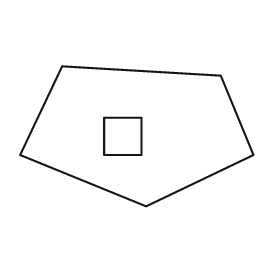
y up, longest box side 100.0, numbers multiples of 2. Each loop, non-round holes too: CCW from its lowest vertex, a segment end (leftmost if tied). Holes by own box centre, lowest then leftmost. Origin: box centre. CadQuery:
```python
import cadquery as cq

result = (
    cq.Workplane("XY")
    .moveTo(4.0, -30.0)
    .lineTo(50.0, -8.0)
    .lineTo(36.0, 26.0)
    .lineTo(-32.0, 30.0)
    .lineTo(-50.0, -8.0)
    .close()
    .moveTo(-14.0, -8.0)
    .lineTo(2.0, -8.0)
    .lineTo(2.0, 8.0)
    .lineTo(-14.0, 8.0)
    .close()
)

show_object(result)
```